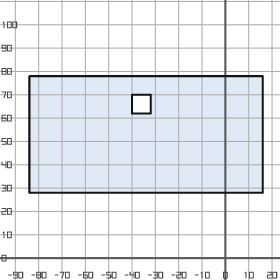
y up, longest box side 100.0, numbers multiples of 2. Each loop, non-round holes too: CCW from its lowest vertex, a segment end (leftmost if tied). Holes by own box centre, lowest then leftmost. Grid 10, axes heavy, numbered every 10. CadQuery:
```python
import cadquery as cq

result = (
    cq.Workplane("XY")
    .moveTo(-84.0, 28.0)
    .lineTo(16.0, 28.0)
    .lineTo(16.0, 78.0)
    .lineTo(-84.0, 78.0)
    .close()
    .moveTo(-40.0, 62.0)
    .lineTo(-32.0, 62.0)
    .lineTo(-32.0, 70.0)
    .lineTo(-40.0, 70.0)
    .close()
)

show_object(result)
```